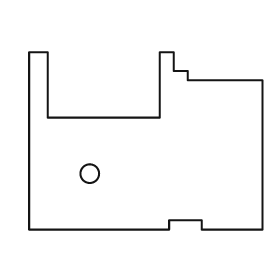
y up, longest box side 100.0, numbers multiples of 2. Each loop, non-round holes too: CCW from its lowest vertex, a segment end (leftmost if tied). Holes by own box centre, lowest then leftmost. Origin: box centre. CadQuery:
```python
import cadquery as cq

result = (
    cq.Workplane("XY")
    .moveTo(-50.0, -38.0)
    .lineTo(10.0, -38.0)
    .lineTo(10.0, -34.0)
    .lineTo(24.0, -34.0)
    .lineTo(24.0, -38.0)
    .lineTo(50.0, -38.0)
    .lineTo(50.0, 26.0)
    .lineTo(18.0, 26.0)
    .lineTo(18.0, 30.0)
    .lineTo(12.0, 30.0)
    .lineTo(12.0, 38.0)
    .lineTo(6.0, 38.0)
    .lineTo(6.0, 10.0)
    .lineTo(-42.0, 10.0)
    .lineTo(-42.0, 38.0)
    .lineTo(-50.0, 38.0)
    .close()
    .moveTo(-24.0, -14.0)
    .circle(4.0)
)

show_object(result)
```